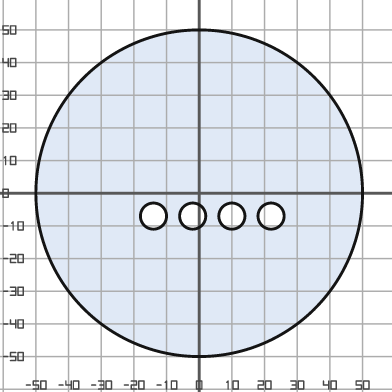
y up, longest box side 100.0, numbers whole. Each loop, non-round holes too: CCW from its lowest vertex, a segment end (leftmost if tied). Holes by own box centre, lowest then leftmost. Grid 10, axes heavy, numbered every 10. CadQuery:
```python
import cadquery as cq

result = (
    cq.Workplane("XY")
    .moveTo(0.0, 0.0)
    .circle(50.0)
    .moveTo(-14.0, -7.0)
    .circle(4.0)
    .moveTo(-2.0, -7.0)
    .circle(4.0)
    .moveTo(10.0, -7.0)
    .circle(4.0)
    .moveTo(22.0, -7.0)
    .circle(4.0)
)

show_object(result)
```